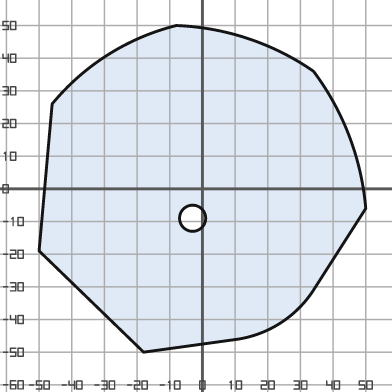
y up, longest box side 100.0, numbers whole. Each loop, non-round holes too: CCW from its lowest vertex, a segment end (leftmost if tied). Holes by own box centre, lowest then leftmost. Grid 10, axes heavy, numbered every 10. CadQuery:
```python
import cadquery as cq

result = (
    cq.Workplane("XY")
    .moveTo(-18.0, -50.0)
    .lineTo(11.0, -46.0)
    .threePointArc((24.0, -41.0), (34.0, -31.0))
    .lineTo(50.0, -6.0)
    .threePointArc((45.0, 16.0), (34.0, 36.0))
    .threePointArc((14.0, 46.0), (-8.0, 50.0))
    .threePointArc((-29.0, 41.0), (-46.0, 26.0))
    .lineTo(-50.0, -19.0)
    .close()
    .moveTo(-3.0, -9.0)
    .circle(4.0)
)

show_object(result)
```